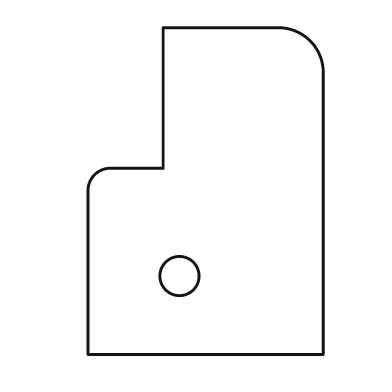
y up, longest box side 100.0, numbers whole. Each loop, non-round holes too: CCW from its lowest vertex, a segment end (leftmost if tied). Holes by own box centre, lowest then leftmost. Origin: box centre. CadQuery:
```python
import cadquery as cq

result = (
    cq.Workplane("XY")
    .moveTo(-36.0, -50.0)
    .lineTo(36.0, -50.0)
    .lineTo(36.0, 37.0)
    .threePointArc((32.0, 46.0), (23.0, 50.0))
    .lineTo(-13.0, 50.0)
    .lineTo(-13.0, 7.0)
    .lineTo(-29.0, 7.0)
    .threePointArc((-34.0, 5.0), (-36.0, 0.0))
    .close()
    .moveTo(-8.0, -26.0)
    .circle(6.0)
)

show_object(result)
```